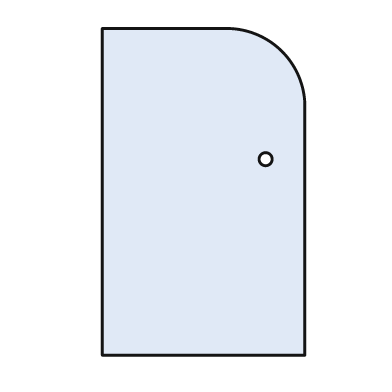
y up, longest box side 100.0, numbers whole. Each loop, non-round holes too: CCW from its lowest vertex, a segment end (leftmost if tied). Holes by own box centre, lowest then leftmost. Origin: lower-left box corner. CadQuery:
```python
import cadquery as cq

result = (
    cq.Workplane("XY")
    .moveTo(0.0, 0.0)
    .lineTo(62.0, 0.0)
    .lineTo(62.0, 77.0)
    .threePointArc((55.0, 93.0), (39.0, 100.0))
    .lineTo(0.0, 100.0)
    .close()
    .moveTo(50.0, 60.0)
    .circle(2.0)
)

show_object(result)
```